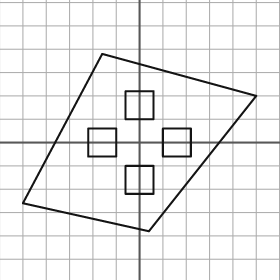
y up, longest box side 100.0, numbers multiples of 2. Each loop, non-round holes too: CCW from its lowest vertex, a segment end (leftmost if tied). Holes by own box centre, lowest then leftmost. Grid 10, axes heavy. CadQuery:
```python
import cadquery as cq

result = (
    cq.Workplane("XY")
    .moveTo(4.0, -38.0)
    .lineTo(50.0, 20.0)
    .lineTo(-16.0, 38.0)
    .lineTo(-50.0, -26.0)
    .close()
    .moveTo(-6.0, -22.0)
    .lineTo(6.0, -22.0)
    .lineTo(6.0, -10.0)
    .lineTo(-6.0, -10.0)
    .close()
    .moveTo(-22.0, -6.0)
    .lineTo(-10.0, -6.0)
    .lineTo(-10.0, 6.0)
    .lineTo(-22.0, 6.0)
    .close()
    .moveTo(10.0, -6.0)
    .lineTo(22.0, -6.0)
    .lineTo(22.0, 6.0)
    .lineTo(10.0, 6.0)
    .close()
    .moveTo(-6.0, 10.0)
    .lineTo(6.0, 10.0)
    .lineTo(6.0, 22.0)
    .lineTo(-6.0, 22.0)
    .close()
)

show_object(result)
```